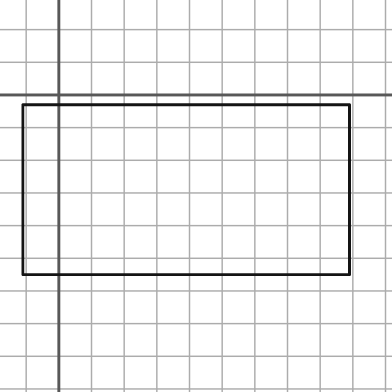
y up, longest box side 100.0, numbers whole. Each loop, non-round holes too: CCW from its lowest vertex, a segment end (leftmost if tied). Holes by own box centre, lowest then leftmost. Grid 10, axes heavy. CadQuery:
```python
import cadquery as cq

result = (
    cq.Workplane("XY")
    .moveTo(-11.0, -55.0)
    .lineTo(89.0, -55.0)
    .lineTo(89.0, -3.0)
    .lineTo(-11.0, -3.0)
    .close()
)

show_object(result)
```